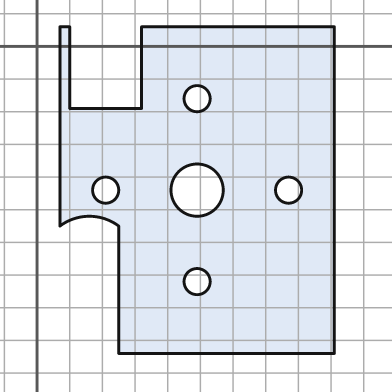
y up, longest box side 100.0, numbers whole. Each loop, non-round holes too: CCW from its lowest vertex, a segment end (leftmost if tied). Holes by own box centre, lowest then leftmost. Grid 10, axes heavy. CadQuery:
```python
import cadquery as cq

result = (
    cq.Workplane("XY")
    .moveTo(25.0, -94.0)
    .lineTo(91.0, -94.0)
    .lineTo(91.0, 6.0)
    .lineTo(32.0, 6.0)
    .lineTo(32.0, -19.0)
    .lineTo(10.0, -19.0)
    .lineTo(10.0, 6.0)
    .lineTo(7.0, 6.0)
    .lineTo(7.0, -55.0)
    .threePointArc((16.0, -52.0), (25.0, -55.0))
    .close()
    .moveTo(49.0, -72.0)
    .circle(4.0)
    .moveTo(21.0, -44.0)
    .circle(4.0)
    .moveTo(49.0, -44.0)
    .circle(8.0)
    .moveTo(77.0, -44.0)
    .circle(4.0)
    .moveTo(49.0, -16.0)
    .circle(4.0)
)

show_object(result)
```